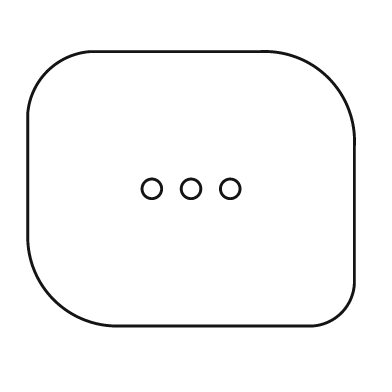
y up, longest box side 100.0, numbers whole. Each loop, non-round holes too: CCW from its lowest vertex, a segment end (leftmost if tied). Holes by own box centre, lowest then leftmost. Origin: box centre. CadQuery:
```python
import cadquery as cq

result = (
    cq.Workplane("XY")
    .moveTo(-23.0, -42.0)
    .lineTo(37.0, -42.0)
    .threePointArc((46.0, -38.0), (50.0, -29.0))
    .lineTo(50.0, 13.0)
    .threePointArc((42.0, 34.0), (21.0, 42.0))
    .lineTo(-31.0, 42.0)
    .threePointArc((-44.0, 36.0), (-50.0, 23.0))
    .lineTo(-50.0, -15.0)
    .threePointArc((-42.0, -34.0), (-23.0, -42.0))
    .close()
    .moveTo(-12.0, 0.0)
    .circle(3.0)
    .moveTo(0.0, 0.0)
    .circle(3.0)
    .moveTo(12.0, 0.0)
    .circle(3.0)
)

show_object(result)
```